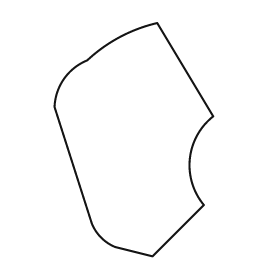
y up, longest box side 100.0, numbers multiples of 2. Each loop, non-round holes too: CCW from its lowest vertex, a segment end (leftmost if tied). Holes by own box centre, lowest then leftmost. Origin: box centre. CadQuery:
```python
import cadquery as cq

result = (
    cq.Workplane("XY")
    .moveTo(8.0, -50.0)
    .lineTo(30.0, -28.0)
    .threePointArc((24.0, -8.0), (34.0, 10.0))
    .lineTo(10.0, 50.0)
    .threePointArc((-6.0, 44.0), (-20.0, 34.0))
    .threePointArc((-30.0, 26.0), (-34.0, 14.0))
    .lineTo(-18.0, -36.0)
    .threePointArc((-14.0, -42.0), (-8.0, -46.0))
    .close()
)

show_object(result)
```